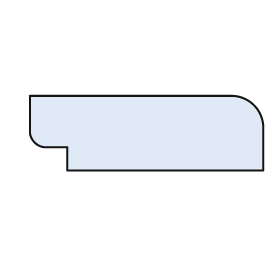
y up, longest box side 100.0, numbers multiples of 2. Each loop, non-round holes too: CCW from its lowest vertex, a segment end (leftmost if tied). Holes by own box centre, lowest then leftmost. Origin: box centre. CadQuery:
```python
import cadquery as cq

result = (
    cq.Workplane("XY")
    .moveTo(-34.0, -16.0)
    .lineTo(50.0, -16.0)
    .lineTo(50.0, 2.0)
    .threePointArc((46.0, 12.0), (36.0, 16.0))
    .lineTo(-50.0, 16.0)
    .lineTo(-50.0, 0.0)
    .threePointArc((-48.0, -4.0), (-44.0, -6.0))
    .lineTo(-34.0, -6.0)
    .close()
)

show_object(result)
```